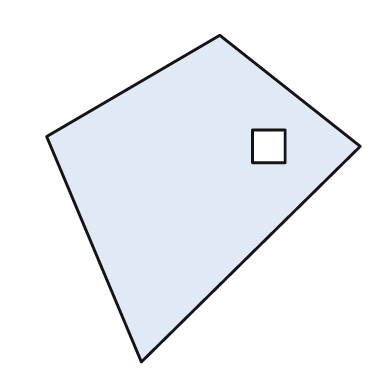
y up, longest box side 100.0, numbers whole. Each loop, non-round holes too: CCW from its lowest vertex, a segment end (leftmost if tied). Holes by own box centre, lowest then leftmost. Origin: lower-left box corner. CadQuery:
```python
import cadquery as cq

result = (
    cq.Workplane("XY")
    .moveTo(29.0, 0.0)
    .lineTo(96.0, 66.0)
    .lineTo(53.0, 100.0)
    .lineTo(0.0, 69.0)
    .close()
    .moveTo(63.0, 61.0)
    .lineTo(73.0, 61.0)
    .lineTo(73.0, 71.0)
    .lineTo(63.0, 71.0)
    .close()
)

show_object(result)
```